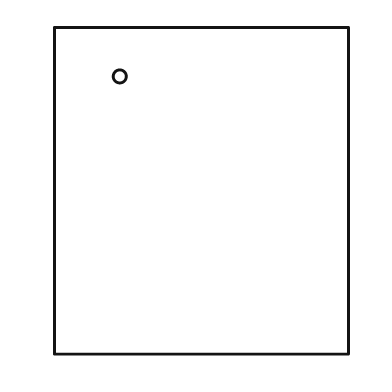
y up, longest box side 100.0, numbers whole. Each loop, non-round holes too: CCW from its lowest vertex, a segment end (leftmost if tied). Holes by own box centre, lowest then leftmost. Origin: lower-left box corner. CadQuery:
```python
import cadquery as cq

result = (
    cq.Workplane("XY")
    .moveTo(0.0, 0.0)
    .lineTo(90.0, 0.0)
    .lineTo(90.0, 100.0)
    .lineTo(0.0, 100.0)
    .close()
    .moveTo(20.0, 85.0)
    .circle(2.0)
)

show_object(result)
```